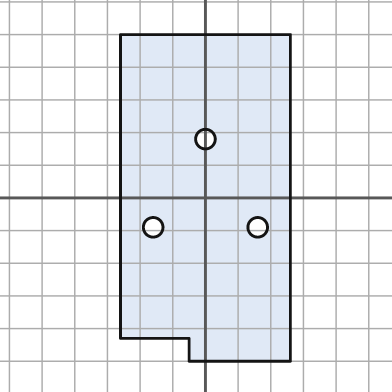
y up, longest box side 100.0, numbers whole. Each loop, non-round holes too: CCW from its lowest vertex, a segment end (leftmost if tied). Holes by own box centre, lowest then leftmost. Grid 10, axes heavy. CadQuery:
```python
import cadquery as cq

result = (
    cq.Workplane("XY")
    .moveTo(-5.0, -50.0)
    .lineTo(26.0, -50.0)
    .lineTo(26.0, 50.0)
    .lineTo(-26.0, 50.0)
    .lineTo(-26.0, -43.0)
    .lineTo(-5.0, -43.0)
    .close()
    .moveTo(-16.0, -9.0)
    .circle(3.0)
    .moveTo(16.0, -9.0)
    .circle(3.0)
    .moveTo(0.0, 18.0)
    .circle(3.0)
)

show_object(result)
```